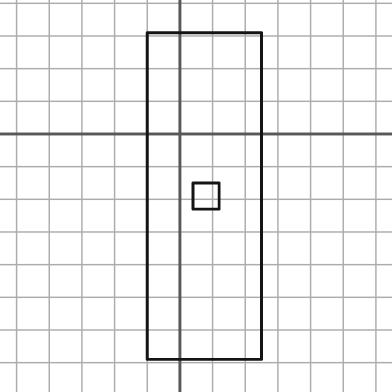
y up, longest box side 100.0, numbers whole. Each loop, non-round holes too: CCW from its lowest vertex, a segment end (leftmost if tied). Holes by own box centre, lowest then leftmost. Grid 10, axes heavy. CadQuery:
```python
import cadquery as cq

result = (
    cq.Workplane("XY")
    .moveTo(-10.0, -69.0)
    .lineTo(25.0, -69.0)
    .lineTo(25.0, 31.0)
    .lineTo(-10.0, 31.0)
    .close()
    .moveTo(4.0, -23.0)
    .lineTo(12.0, -23.0)
    .lineTo(12.0, -15.0)
    .lineTo(4.0, -15.0)
    .close()
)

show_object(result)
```